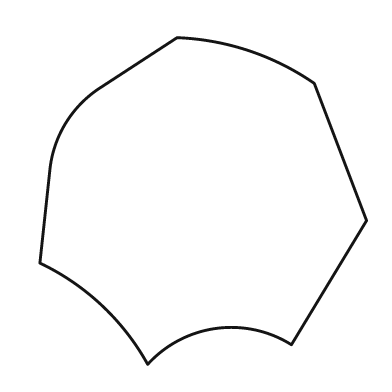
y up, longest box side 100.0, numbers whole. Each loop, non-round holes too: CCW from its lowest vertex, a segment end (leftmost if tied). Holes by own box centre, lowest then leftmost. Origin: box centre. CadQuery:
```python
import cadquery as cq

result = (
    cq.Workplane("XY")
    .moveTo(-17.0, -50.0)
    .threePointArc((4.0, -39.0), (27.0, -44.0))
    .lineTo(50.0, -6.0)
    .lineTo(34.0, 36.0)
    .threePointArc((14.0, 46.0), (-8.0, 50.0))
    .lineTo(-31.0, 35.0)
    .threePointArc((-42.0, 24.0), (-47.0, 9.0))
    .lineTo(-50.0, -19.0)
    .threePointArc((-31.0, -32.0), (-17.0, -50.0))
    .close()
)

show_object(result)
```